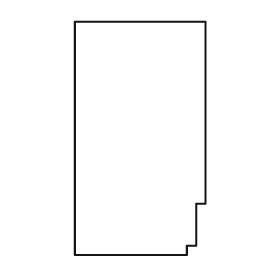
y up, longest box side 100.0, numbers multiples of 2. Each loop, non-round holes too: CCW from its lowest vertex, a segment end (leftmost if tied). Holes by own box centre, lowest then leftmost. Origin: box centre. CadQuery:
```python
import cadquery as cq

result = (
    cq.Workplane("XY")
    .moveTo(-28.0, -50.0)
    .lineTo(20.0, -50.0)
    .lineTo(20.0, -46.0)
    .lineTo(24.0, -46.0)
    .lineTo(24.0, -28.0)
    .lineTo(28.0, -28.0)
    .lineTo(28.0, 50.0)
    .lineTo(-28.0, 50.0)
    .close()
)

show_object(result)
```